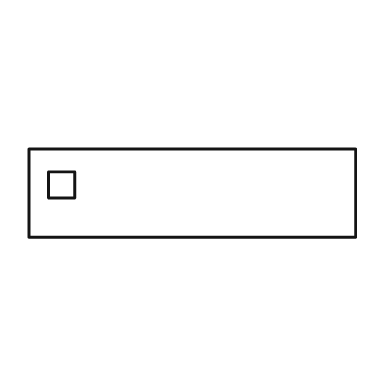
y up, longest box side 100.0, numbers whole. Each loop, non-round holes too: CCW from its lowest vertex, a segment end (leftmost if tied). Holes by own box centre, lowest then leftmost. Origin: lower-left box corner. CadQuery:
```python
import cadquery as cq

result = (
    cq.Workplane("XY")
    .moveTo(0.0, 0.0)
    .lineTo(100.0, 0.0)
    .lineTo(100.0, 27.0)
    .lineTo(0.0, 27.0)
    .close()
    .moveTo(6.0, 12.0)
    .lineTo(14.0, 12.0)
    .lineTo(14.0, 20.0)
    .lineTo(6.0, 20.0)
    .close()
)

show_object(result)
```